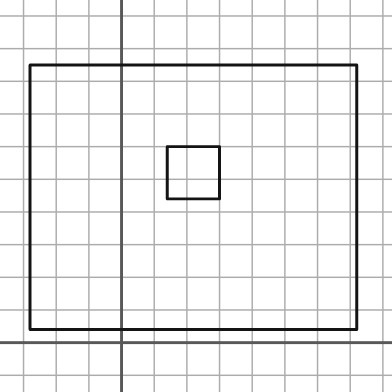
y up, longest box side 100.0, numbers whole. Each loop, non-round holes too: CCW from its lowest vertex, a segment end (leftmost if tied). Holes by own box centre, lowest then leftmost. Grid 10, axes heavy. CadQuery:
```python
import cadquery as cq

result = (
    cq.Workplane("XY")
    .moveTo(-28.0, 4.0)
    .lineTo(72.0, 4.0)
    .lineTo(72.0, 85.0)
    .lineTo(-28.0, 85.0)
    .close()
    .moveTo(14.0, 44.0)
    .lineTo(30.0, 44.0)
    .lineTo(30.0, 60.0)
    .lineTo(14.0, 60.0)
    .close()
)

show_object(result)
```